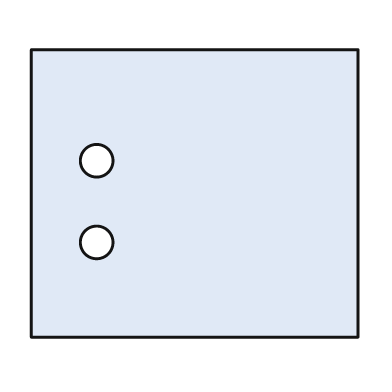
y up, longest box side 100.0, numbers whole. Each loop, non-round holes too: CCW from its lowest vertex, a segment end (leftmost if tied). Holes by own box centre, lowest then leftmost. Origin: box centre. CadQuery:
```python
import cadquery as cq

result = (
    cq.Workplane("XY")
    .moveTo(-50.0, -44.0)
    .lineTo(50.0, -44.0)
    .lineTo(50.0, 44.0)
    .lineTo(-50.0, 44.0)
    .close()
    .moveTo(-30.0, -15.0)
    .circle(5.0)
    .moveTo(-30.0, 10.0)
    .circle(5.0)
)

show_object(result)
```